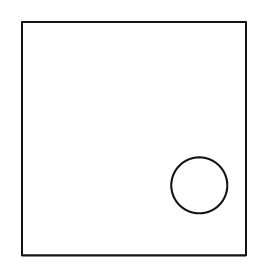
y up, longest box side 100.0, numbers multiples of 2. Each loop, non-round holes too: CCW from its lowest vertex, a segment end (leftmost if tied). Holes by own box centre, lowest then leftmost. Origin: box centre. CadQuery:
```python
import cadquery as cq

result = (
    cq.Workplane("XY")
    .moveTo(-48.0, -50.0)
    .lineTo(48.0, -50.0)
    .lineTo(48.0, 50.0)
    .lineTo(-48.0, 50.0)
    .close()
    .moveTo(28.0, -20.0)
    .circle(12.0)
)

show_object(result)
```